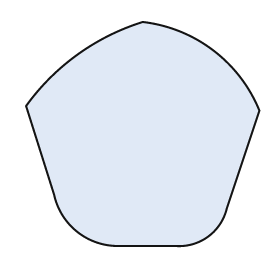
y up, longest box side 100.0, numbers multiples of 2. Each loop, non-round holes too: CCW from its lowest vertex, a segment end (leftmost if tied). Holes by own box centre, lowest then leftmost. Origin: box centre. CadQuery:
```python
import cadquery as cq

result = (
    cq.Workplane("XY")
    .moveTo(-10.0, -48.0)
    .lineTo(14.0, -48.0)
    .threePointArc((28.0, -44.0), (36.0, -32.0))
    .lineTo(50.0, 10.0)
    .threePointArc((30.0, 36.0), (0.0, 48.0))
    .threePointArc((-28.0, 34.0), (-50.0, 12.0))
    .lineTo(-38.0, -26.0)
    .threePointArc((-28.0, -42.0), (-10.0, -48.0))
    .close()
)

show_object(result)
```